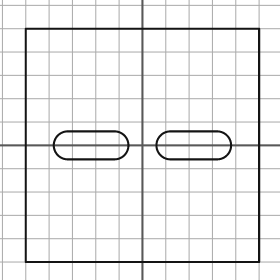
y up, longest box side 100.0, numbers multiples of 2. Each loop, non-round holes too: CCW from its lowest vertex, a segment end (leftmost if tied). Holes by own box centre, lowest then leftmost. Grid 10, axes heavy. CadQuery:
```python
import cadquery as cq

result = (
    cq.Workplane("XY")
    .moveTo(-50.0, -50.0)
    .lineTo(50.0, -50.0)
    .lineTo(50.0, 50.0)
    .lineTo(-50.0, 50.0)
    .close()
    .moveTo(-32.0, -6.0)
    .lineTo(-12.0, -6.0)
    .threePointArc((-6.0, 0.0), (-12.0, 6.0))
    .lineTo(-32.0, 6.0)
    .threePointArc((-38.0, 0.0), (-32.0, -6.0))
    .close()
    .moveTo(12.0, -6.0)
    .lineTo(32.0, -6.0)
    .threePointArc((38.0, 0.0), (32.0, 6.0))
    .lineTo(12.0, 6.0)
    .threePointArc((6.0, 0.0), (12.0, -6.0))
    .close()
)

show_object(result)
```